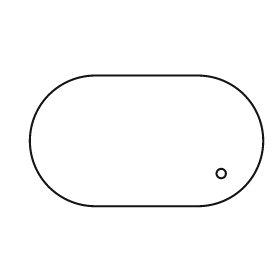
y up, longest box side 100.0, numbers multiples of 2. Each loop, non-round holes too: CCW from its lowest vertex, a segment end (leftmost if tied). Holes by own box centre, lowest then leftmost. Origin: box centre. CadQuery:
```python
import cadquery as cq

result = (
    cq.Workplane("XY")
    .moveTo(-22.0, -28.0)
    .lineTo(22.0, -28.0)
    .threePointArc((50.0, 0.0), (22.0, 28.0))
    .lineTo(-22.0, 28.0)
    .threePointArc((-50.0, 0.0), (-22.0, -28.0))
    .close()
    .moveTo(32.0, -14.0)
    .circle(2.0)
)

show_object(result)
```